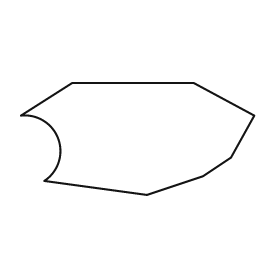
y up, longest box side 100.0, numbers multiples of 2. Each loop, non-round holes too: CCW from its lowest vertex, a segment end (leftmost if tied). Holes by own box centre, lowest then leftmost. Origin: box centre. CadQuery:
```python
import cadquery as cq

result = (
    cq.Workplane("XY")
    .moveTo(4.0, -24.0)
    .lineTo(28.0, -16.0)
    .lineTo(40.0, -8.0)
    .lineTo(50.0, 10.0)
    .lineTo(24.0, 24.0)
    .lineTo(-28.0, 24.0)
    .lineTo(-50.0, 10.0)
    .threePointArc((-34.0, 0.0), (-40.0, -18.0))
    .close()
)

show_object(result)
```